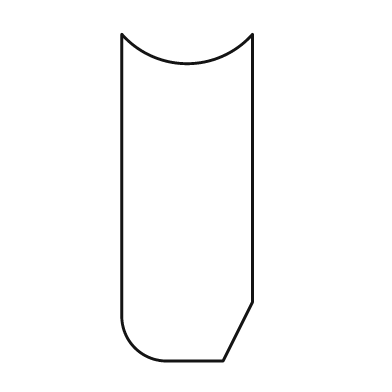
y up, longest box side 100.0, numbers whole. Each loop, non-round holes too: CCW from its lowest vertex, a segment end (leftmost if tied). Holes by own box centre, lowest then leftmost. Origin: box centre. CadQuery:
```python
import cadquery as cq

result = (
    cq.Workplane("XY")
    .moveTo(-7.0, -50.0)
    .lineTo(11.0, -50.0)
    .lineTo(20.0, -32.0)
    .lineTo(20.0, 50.0)
    .threePointArc((0.0, 41.0), (-20.0, 50.0))
    .lineTo(-20.0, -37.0)
    .threePointArc((-16.0, -46.0), (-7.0, -50.0))
    .close()
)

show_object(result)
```